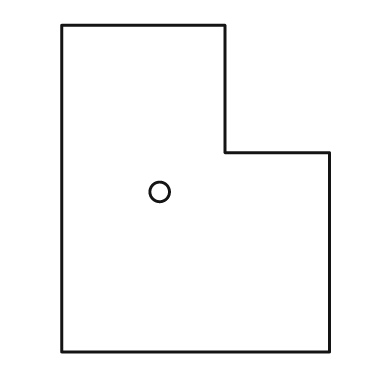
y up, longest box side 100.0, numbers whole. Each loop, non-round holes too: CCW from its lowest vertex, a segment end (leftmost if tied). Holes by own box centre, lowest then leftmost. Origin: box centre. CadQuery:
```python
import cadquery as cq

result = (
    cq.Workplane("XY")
    .moveTo(-41.0, -50.0)
    .lineTo(41.0, -50.0)
    .lineTo(41.0, 11.0)
    .lineTo(9.0, 11.0)
    .lineTo(9.0, 50.0)
    .lineTo(-41.0, 50.0)
    .close()
    .moveTo(-11.0, -1.0)
    .circle(3.0)
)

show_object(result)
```